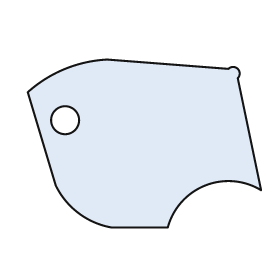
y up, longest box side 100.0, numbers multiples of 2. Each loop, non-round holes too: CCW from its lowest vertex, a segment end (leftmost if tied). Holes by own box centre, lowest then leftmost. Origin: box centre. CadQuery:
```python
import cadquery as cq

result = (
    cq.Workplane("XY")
    .moveTo(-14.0, -36.0)
    .lineTo(10.0, -36.0)
    .threePointArc((26.0, -18.0), (50.0, -20.0))
    .lineTo(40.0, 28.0)
    .threePointArc((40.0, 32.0), (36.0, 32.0))
    .lineTo(-16.0, 36.0)
    .threePointArc((-34.0, 32.0), (-50.0, 22.0))
    .lineTo(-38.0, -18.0)
    .threePointArc((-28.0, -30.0), (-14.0, -36.0))
    .close()
    .moveTo(-34.0, 10.0)
    .circle(6.0)
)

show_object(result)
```